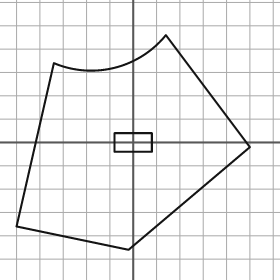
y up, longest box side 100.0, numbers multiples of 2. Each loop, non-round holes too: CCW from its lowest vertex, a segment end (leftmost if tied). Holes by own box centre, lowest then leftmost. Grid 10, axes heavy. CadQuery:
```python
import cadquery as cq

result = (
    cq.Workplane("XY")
    .moveTo(-2.0, -46.0)
    .lineTo(50.0, -2.0)
    .lineTo(14.0, 46.0)
    .threePointArc((-8.0, 32.0), (-34.0, 34.0))
    .lineTo(-50.0, -36.0)
    .close()
    .moveTo(-8.0, -4.0)
    .lineTo(8.0, -4.0)
    .lineTo(8.0, 4.0)
    .lineTo(-8.0, 4.0)
    .close()
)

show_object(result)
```